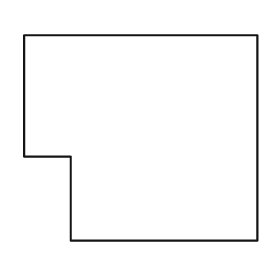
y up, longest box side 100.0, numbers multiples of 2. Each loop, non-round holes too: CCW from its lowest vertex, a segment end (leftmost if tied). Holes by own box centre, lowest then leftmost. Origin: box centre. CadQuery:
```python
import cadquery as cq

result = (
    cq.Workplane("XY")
    .moveTo(-30.0, -44.0)
    .lineTo(50.0, -44.0)
    .lineTo(50.0, 44.0)
    .lineTo(-50.0, 44.0)
    .lineTo(-50.0, -8.0)
    .lineTo(-30.0, -8.0)
    .close()
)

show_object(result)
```